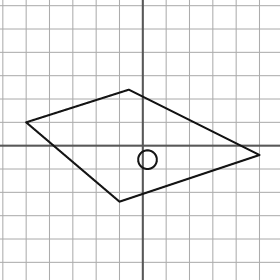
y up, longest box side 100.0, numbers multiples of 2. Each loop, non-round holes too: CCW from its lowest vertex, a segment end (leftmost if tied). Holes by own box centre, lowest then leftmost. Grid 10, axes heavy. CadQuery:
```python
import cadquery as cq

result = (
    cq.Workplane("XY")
    .moveTo(-10.0, -24.0)
    .lineTo(50.0, -4.0)
    .lineTo(-6.0, 24.0)
    .lineTo(-50.0, 10.0)
    .close()
    .moveTo(2.0, -6.0)
    .circle(4.0)
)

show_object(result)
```